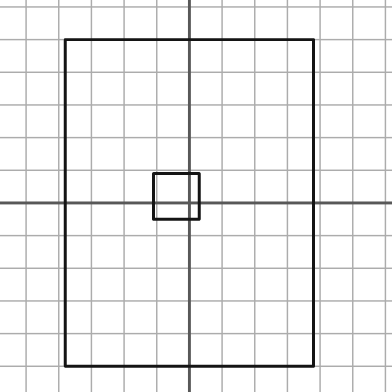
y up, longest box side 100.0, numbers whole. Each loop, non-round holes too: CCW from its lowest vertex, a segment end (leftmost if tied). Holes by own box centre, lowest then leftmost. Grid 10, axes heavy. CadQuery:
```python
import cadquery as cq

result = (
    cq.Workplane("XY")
    .moveTo(-38.0, -50.0)
    .lineTo(38.0, -50.0)
    .lineTo(38.0, 50.0)
    .lineTo(-38.0, 50.0)
    .close()
    .moveTo(-11.0, -5.0)
    .lineTo(3.0, -5.0)
    .lineTo(3.0, 9.0)
    .lineTo(-11.0, 9.0)
    .close()
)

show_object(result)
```